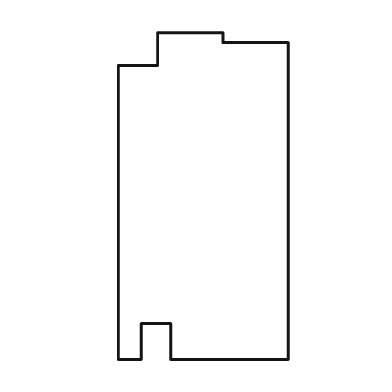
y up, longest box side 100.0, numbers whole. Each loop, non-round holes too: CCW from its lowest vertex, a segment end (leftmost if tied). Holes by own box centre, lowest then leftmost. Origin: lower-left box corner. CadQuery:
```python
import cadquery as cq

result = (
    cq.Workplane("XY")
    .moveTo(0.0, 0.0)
    .lineTo(7.0, 0.0)
    .lineTo(7.0, 11.0)
    .lineTo(16.0, 11.0)
    .lineTo(16.0, 0.0)
    .lineTo(52.0, 0.0)
    .lineTo(52.0, 97.0)
    .lineTo(32.0, 97.0)
    .lineTo(32.0, 100.0)
    .lineTo(12.0, 100.0)
    .lineTo(12.0, 90.0)
    .lineTo(0.0, 90.0)
    .close()
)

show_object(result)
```